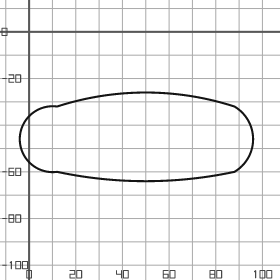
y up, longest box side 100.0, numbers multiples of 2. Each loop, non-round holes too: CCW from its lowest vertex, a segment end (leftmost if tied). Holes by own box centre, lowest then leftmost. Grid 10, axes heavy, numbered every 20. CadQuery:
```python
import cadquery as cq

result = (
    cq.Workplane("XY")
    .moveTo(12.0, -60.0)
    .threePointArc((50.0, -64.0), (88.0, -60.0))
    .threePointArc((96.0, -46.0), (88.0, -32.0))
    .threePointArc((50.0, -26.0), (12.0, -32.0))
    .threePointArc((-4.0, -46.0), (12.0, -60.0))
    .close()
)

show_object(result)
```